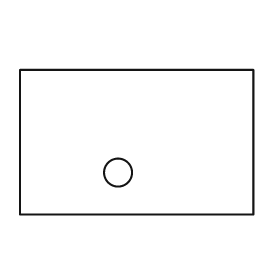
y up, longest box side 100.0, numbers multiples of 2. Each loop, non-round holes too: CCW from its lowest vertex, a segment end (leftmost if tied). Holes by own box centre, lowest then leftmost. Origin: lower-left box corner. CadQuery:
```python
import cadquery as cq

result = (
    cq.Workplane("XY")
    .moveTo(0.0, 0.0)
    .lineTo(100.0, 0.0)
    .lineTo(100.0, 62.0)
    .lineTo(0.0, 62.0)
    .close()
    .moveTo(42.0, 18.0)
    .circle(6.0)
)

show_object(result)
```